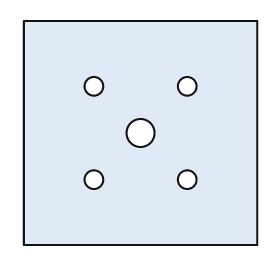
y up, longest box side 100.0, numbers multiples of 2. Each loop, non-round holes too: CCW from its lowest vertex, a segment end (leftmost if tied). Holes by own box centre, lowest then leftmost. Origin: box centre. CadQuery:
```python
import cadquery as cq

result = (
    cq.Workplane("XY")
    .moveTo(-50.0, -48.0)
    .lineTo(50.0, -48.0)
    .lineTo(50.0, 48.0)
    .lineTo(-50.0, 48.0)
    .close()
    .moveTo(-20.0, -20.0)
    .circle(4.0)
    .moveTo(20.0, -20.0)
    .circle(4.0)
    .moveTo(0.0, 0.0)
    .circle(6.0)
    .moveTo(-20.0, 20.0)
    .circle(4.0)
    .moveTo(20.0, 20.0)
    .circle(4.0)
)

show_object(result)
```